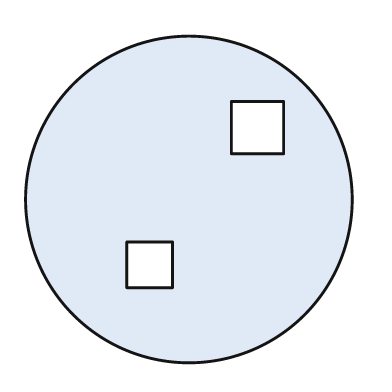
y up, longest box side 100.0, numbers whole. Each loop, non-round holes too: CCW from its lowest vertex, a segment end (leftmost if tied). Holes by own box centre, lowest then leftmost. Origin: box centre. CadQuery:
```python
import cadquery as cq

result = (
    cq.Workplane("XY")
    .moveTo(0.0, 0.0)
    .circle(50.0)
    .moveTo(-19.0, -27.0)
    .lineTo(-5.0, -27.0)
    .lineTo(-5.0, -13.0)
    .lineTo(-19.0, -13.0)
    .close()
    .moveTo(13.0, 14.0)
    .lineTo(29.0, 14.0)
    .lineTo(29.0, 30.0)
    .lineTo(13.0, 30.0)
    .close()
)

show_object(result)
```